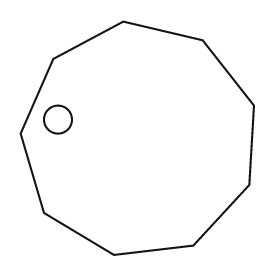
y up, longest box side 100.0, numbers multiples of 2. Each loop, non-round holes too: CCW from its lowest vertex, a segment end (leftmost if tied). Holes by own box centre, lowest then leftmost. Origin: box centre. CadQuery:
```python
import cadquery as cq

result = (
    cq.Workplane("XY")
    .moveTo(-10.0, -50.0)
    .lineTo(24.0, -46.0)
    .lineTo(48.0, -20.0)
    .lineTo(50.0, 14.0)
    .lineTo(28.0, 42.0)
    .lineTo(-6.0, 50.0)
    .lineTo(-36.0, 34.0)
    .lineTo(-50.0, 2.0)
    .lineTo(-40.0, -32.0)
    .close()
    .moveTo(-34.0, 8.0)
    .circle(6.0)
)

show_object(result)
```